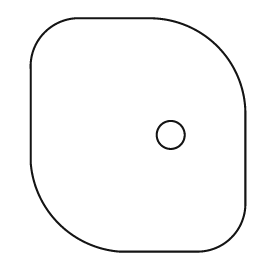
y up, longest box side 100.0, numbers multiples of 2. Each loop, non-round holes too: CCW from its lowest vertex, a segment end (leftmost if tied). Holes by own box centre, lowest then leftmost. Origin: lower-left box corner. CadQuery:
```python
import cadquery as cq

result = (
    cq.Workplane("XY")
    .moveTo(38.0, 0.0)
    .lineTo(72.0, 0.0)
    .threePointArc((86.0, 6.0), (92.0, 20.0))
    .lineTo(92.0, 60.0)
    .threePointArc((80.0, 88.0), (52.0, 100.0))
    .lineTo(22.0, 100.0)
    .threePointArc((6.0, 94.0), (0.0, 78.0))
    .lineTo(0.0, 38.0)
    .threePointArc((12.0, 12.0), (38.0, 0.0))
    .close()
    .moveTo(60.0, 50.0)
    .circle(6.0)
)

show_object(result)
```